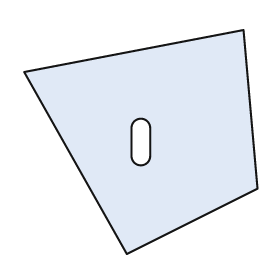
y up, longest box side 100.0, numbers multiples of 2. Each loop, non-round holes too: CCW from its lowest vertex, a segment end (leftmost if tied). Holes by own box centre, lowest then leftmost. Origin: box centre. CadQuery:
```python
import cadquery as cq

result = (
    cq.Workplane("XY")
    .moveTo(-6.0, -48.0)
    .lineTo(50.0, -20.0)
    .lineTo(44.0, 48.0)
    .lineTo(-50.0, 30.0)
    .close()
    .moveTo(-4.0, -6.0)
    .threePointArc((0.0, -10.0), (4.0, -6.0))
    .lineTo(4.0, 6.0)
    .threePointArc((0.0, 10.0), (-4.0, 6.0))
    .close()
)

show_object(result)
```